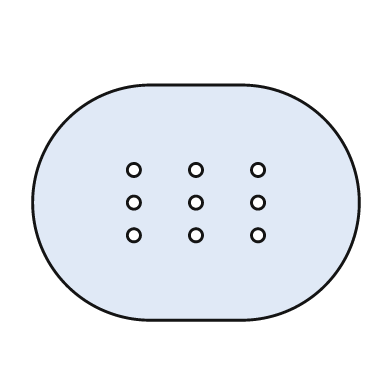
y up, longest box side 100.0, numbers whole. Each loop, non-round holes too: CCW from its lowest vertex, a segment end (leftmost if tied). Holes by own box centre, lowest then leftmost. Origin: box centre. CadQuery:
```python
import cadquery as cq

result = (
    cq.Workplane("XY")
    .moveTo(-14.0, -36.0)
    .lineTo(14.0, -36.0)
    .threePointArc((50.0, 0.0), (14.0, 36.0))
    .lineTo(-14.0, 36.0)
    .threePointArc((-50.0, 0.0), (-14.0, -36.0))
    .close()
    .moveTo(-19.0, -10.0)
    .circle(2.0)
    .moveTo(0.0, -10.0)
    .circle(2.0)
    .moveTo(19.0, -10.0)
    .circle(2.0)
    .moveTo(-19.0, 0.0)
    .circle(2.0)
    .moveTo(0.0, 0.0)
    .circle(2.0)
    .moveTo(19.0, 0.0)
    .circle(2.0)
    .moveTo(-19.0, 10.0)
    .circle(2.0)
    .moveTo(0.0, 10.0)
    .circle(2.0)
    .moveTo(19.0, 10.0)
    .circle(2.0)
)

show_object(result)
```